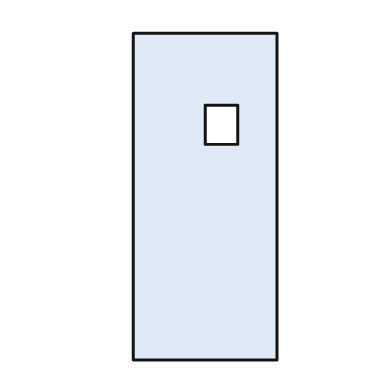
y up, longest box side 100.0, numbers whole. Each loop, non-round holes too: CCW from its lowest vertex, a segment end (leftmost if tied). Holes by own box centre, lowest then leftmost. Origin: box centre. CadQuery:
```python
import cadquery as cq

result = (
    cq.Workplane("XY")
    .moveTo(-22.0, -50.0)
    .lineTo(22.0, -50.0)
    .lineTo(22.0, 50.0)
    .lineTo(-22.0, 50.0)
    .close()
    .moveTo(0.0, 16.0)
    .lineTo(10.0, 16.0)
    .lineTo(10.0, 28.0)
    .lineTo(0.0, 28.0)
    .close()
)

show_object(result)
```